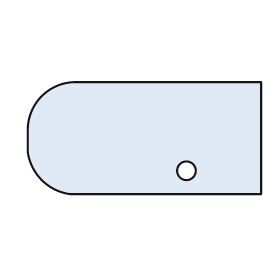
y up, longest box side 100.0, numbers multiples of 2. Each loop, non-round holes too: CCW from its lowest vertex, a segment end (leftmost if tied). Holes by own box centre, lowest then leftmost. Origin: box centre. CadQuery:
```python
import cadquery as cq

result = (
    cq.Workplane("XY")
    .moveTo(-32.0, -24.0)
    .lineTo(50.0, -24.0)
    .lineTo(50.0, 24.0)
    .lineTo(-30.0, 24.0)
    .threePointArc((-44.0, 18.0), (-50.0, 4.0))
    .lineTo(-50.0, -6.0)
    .threePointArc((-44.0, -18.0), (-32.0, -24.0))
    .close()
    .moveTo(18.0, -14.0)
    .circle(4.0)
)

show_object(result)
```